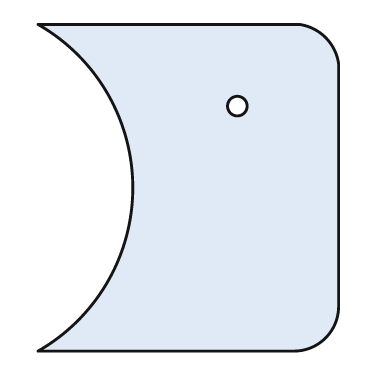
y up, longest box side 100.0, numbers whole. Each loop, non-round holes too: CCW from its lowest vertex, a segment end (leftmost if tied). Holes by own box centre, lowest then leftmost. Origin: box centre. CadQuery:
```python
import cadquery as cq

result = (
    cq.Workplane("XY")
    .moveTo(-46.0, -50.0)
    .lineTo(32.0, -50.0)
    .threePointArc((42.0, -46.0), (46.0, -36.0))
    .lineTo(46.0, 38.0)
    .threePointArc((42.0, 46.0), (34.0, 50.0))
    .lineTo(-46.0, 50.0)
    .threePointArc((-17.0, 0.0), (-46.0, -50.0))
    .close()
    .moveTo(15.0, 25.0)
    .circle(3.0)
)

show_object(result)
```